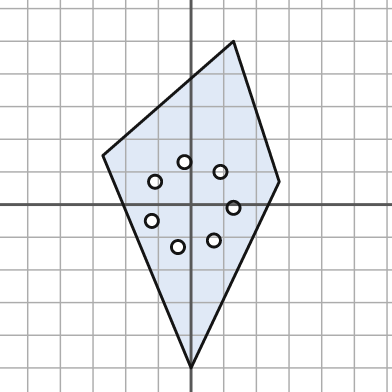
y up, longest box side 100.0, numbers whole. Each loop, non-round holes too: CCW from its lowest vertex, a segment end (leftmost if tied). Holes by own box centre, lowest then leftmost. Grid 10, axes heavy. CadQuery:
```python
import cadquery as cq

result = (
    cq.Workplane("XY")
    .moveTo(0.0, -50.0)
    .lineTo(27.0, 7.0)
    .lineTo(13.0, 50.0)
    .lineTo(-27.0, 15.0)
    .close()
    .moveTo(-4.0, -13.0)
    .circle(2.0)
    .moveTo(7.0, -11.0)
    .circle(2.0)
    .moveTo(-12.0, -5.0)
    .circle(2.0)
    .moveTo(13.0, -1.0)
    .circle(2.0)
    .moveTo(-11.0, 7.0)
    .circle(2.0)
    .moveTo(9.0, 10.0)
    .circle(2.0)
    .moveTo(-2.0, 13.0)
    .circle(2.0)
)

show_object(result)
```